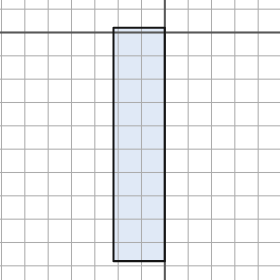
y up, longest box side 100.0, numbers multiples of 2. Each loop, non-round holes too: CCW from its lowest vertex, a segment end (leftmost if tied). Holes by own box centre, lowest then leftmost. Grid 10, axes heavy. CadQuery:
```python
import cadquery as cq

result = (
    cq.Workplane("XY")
    .moveTo(-22.0, -98.0)
    .lineTo(0.0, -98.0)
    .lineTo(0.0, 2.0)
    .lineTo(-22.0, 2.0)
    .close()
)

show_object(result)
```